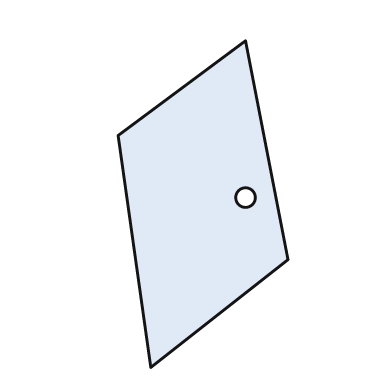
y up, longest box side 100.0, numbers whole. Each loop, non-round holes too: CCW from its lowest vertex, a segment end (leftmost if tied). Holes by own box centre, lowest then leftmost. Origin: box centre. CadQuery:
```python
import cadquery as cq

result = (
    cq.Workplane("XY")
    .moveTo(-16.0, -50.0)
    .lineTo(26.0, -17.0)
    .lineTo(13.0, 50.0)
    .lineTo(-26.0, 21.0)
    .close()
    .moveTo(13.0, 2.0)
    .circle(3.0)
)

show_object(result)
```